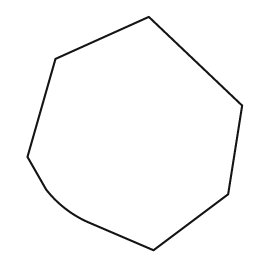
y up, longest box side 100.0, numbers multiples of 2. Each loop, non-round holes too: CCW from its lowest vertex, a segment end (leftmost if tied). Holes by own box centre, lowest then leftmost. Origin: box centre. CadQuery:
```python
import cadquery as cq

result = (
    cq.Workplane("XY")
    .moveTo(8.0, -50.0)
    .lineTo(40.0, -26.0)
    .lineTo(46.0, 12.0)
    .lineTo(6.0, 50.0)
    .lineTo(-34.0, 32.0)
    .lineTo(-46.0, -10.0)
    .lineTo(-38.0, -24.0)
    .threePointArc((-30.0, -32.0), (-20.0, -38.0))
    .close()
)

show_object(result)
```